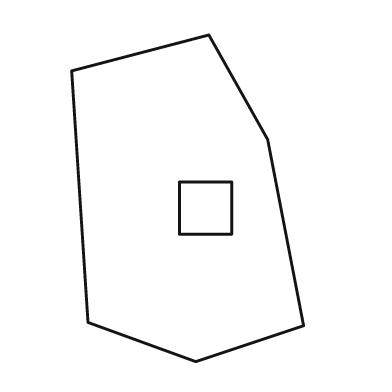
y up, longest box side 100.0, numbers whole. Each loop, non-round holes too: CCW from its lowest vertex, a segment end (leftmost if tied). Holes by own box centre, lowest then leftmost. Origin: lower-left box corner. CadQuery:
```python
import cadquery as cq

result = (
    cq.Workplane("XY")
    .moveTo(38.0, 0.0)
    .lineTo(71.0, 11.0)
    .lineTo(60.0, 68.0)
    .lineTo(42.0, 100.0)
    .lineTo(0.0, 89.0)
    .lineTo(5.0, 12.0)
    .close()
    .moveTo(33.0, 39.0)
    .lineTo(49.0, 39.0)
    .lineTo(49.0, 55.0)
    .lineTo(33.0, 55.0)
    .close()
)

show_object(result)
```